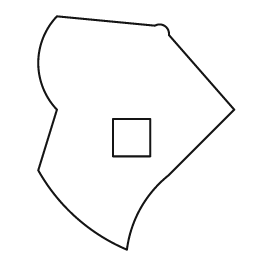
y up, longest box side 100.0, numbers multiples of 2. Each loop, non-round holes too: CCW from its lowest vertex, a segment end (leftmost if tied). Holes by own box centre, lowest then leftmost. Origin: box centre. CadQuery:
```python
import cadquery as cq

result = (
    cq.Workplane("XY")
    .moveTo(-4.0, -50.0)
    .threePointArc((2.0, -32.0), (14.0, -18.0))
    .lineTo(42.0, 10.0)
    .lineTo(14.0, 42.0)
    .threePointArc((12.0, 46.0), (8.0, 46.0))
    .lineTo(-34.0, 50.0)
    .threePointArc((-42.0, 30.0), (-34.0, 10.0))
    .lineTo(-42.0, -16.0)
    .threePointArc((-26.0, -36.0), (-4.0, -50.0))
    .close()
    .moveTo(-10.0, -10.0)
    .lineTo(6.0, -10.0)
    .lineTo(6.0, 6.0)
    .lineTo(-10.0, 6.0)
    .close()
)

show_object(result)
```